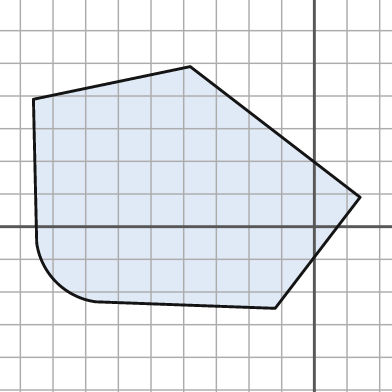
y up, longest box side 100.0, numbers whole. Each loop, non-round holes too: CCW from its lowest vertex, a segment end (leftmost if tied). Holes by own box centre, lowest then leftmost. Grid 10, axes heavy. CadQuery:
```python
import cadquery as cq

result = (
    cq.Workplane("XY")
    .moveTo(-12.0, -25.0)
    .lineTo(14.0, 9.0)
    .lineTo(-38.0, 49.0)
    .lineTo(-86.0, 39.0)
    .lineTo(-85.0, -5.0)
    .threePointArc((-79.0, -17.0), (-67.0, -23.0))
    .close()
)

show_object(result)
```